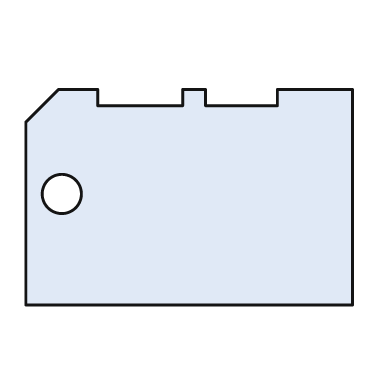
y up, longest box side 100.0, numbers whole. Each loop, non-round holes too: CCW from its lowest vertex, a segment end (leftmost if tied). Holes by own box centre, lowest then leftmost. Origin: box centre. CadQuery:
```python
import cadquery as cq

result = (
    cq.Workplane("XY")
    .moveTo(-50.0, -33.0)
    .lineTo(50.0, -33.0)
    .lineTo(50.0, 33.0)
    .lineTo(27.0, 33.0)
    .lineTo(27.0, 28.0)
    .lineTo(5.0, 28.0)
    .lineTo(5.0, 33.0)
    .lineTo(-2.0, 33.0)
    .lineTo(-2.0, 28.0)
    .lineTo(-28.0, 28.0)
    .lineTo(-28.0, 33.0)
    .lineTo(-40.0, 33.0)
    .lineTo(-50.0, 23.0)
    .close()
    .moveTo(-39.0, 1.0)
    .circle(6.0)
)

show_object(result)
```